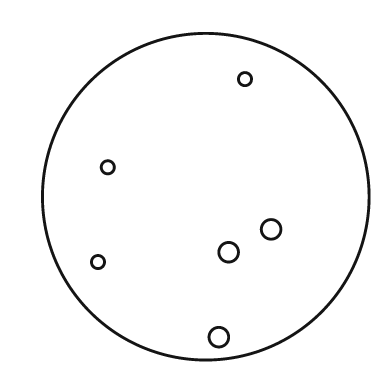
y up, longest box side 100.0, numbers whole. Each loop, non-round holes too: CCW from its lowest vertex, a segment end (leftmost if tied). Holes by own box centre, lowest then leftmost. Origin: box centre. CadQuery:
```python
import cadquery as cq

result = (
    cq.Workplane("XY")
    .moveTo(0.0, 0.0)
    .circle(50.0)
    .moveTo(4.0, -43.0)
    .circle(3.0)
    .moveTo(-33.0, -20.0)
    .circle(2.0)
    .moveTo(7.0, -17.0)
    .circle(3.0)
    .moveTo(20.0, -10.0)
    .circle(3.0)
    .moveTo(-30.0, 9.0)
    .circle(2.0)
    .moveTo(12.0, 36.0)
    .circle(2.0)
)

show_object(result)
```